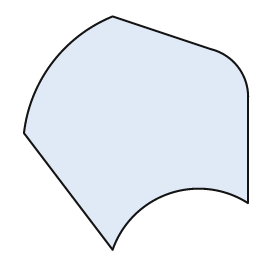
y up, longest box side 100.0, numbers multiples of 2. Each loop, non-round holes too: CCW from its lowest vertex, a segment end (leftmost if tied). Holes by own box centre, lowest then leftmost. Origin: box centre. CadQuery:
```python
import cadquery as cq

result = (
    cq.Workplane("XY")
    .moveTo(-10.0, -50.0)
    .threePointArc((14.0, -26.0), (48.0, -30.0))
    .lineTo(48.0, 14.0)
    .threePointArc((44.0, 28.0), (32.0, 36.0))
    .lineTo(-10.0, 50.0)
    .threePointArc((-36.0, 30.0), (-48.0, 0.0))
    .close()
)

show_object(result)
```